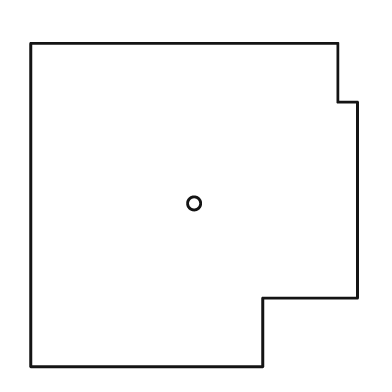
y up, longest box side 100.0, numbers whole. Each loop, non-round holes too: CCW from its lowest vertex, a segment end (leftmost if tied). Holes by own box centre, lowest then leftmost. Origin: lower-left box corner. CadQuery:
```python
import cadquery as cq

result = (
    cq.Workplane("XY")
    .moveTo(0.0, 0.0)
    .lineTo(71.0, 0.0)
    .lineTo(71.0, 21.0)
    .lineTo(100.0, 21.0)
    .lineTo(100.0, 81.0)
    .lineTo(94.0, 81.0)
    .lineTo(94.0, 99.0)
    .lineTo(0.0, 99.0)
    .close()
    .moveTo(50.0, 50.0)
    .circle(2.0)
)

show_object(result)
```